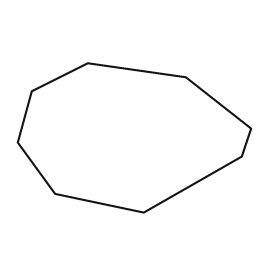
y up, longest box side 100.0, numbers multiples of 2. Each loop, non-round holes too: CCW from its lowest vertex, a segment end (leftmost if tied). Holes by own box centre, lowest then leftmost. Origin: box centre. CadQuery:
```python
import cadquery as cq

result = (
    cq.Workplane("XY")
    .moveTo(4.0, -32.0)
    .lineTo(46.0, -8.0)
    .lineTo(50.0, 4.0)
    .lineTo(22.0, 26.0)
    .lineTo(-20.0, 32.0)
    .lineTo(-44.0, 20.0)
    .lineTo(-50.0, -2.0)
    .lineTo(-34.0, -24.0)
    .close()
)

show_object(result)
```